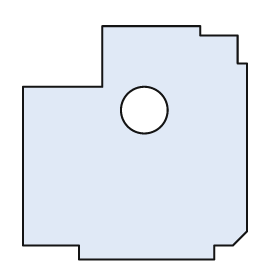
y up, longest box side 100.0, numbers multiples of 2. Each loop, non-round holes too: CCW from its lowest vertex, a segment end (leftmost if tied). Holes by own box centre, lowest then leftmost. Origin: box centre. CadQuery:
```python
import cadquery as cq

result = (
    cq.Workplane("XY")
    .moveTo(-24.0, -50.0)
    .lineTo(34.0, -50.0)
    .lineTo(34.0, -44.0)
    .lineTo(42.0, -44.0)
    .lineTo(48.0, -38.0)
    .lineTo(48.0, 34.0)
    .lineTo(44.0, 34.0)
    .lineTo(44.0, 46.0)
    .lineTo(28.0, 46.0)
    .lineTo(28.0, 50.0)
    .lineTo(-14.0, 50.0)
    .lineTo(-14.0, 24.0)
    .lineTo(-48.0, 24.0)
    .lineTo(-48.0, -44.0)
    .lineTo(-24.0, -44.0)
    .close()
    .moveTo(4.0, 14.0)
    .circle(10.0)
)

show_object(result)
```